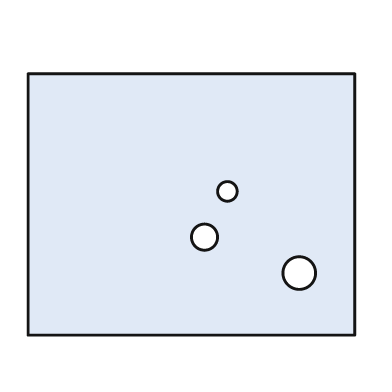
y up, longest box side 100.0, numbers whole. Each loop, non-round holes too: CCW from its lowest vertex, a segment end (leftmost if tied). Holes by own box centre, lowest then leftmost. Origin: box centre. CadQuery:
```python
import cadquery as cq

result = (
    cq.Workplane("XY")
    .moveTo(-50.0, -40.0)
    .lineTo(50.0, -40.0)
    .lineTo(50.0, 40.0)
    .lineTo(-50.0, 40.0)
    .close()
    .moveTo(33.0, -21.0)
    .circle(5.0)
    .moveTo(4.0, -10.0)
    .circle(4.0)
    .moveTo(11.0, 4.0)
    .circle(3.0)
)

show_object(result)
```